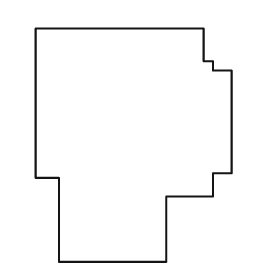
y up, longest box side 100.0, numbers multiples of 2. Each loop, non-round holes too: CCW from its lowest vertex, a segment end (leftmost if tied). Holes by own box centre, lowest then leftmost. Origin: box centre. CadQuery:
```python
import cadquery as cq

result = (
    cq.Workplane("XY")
    .moveTo(-32.0, -50.0)
    .lineTo(14.0, -50.0)
    .lineTo(14.0, -22.0)
    .lineTo(34.0, -22.0)
    .lineTo(34.0, -12.0)
    .lineTo(42.0, -12.0)
    .lineTo(42.0, 32.0)
    .lineTo(34.0, 32.0)
    .lineTo(34.0, 36.0)
    .lineTo(30.0, 36.0)
    .lineTo(30.0, 50.0)
    .lineTo(-42.0, 50.0)
    .lineTo(-42.0, -14.0)
    .lineTo(-32.0, -14.0)
    .close()
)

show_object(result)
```